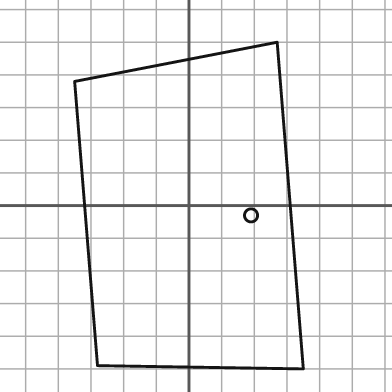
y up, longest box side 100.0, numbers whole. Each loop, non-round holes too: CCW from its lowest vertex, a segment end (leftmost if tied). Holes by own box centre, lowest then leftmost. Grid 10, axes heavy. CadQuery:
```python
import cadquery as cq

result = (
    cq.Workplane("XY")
    .moveTo(35.0, -50.0)
    .lineTo(27.0, 50.0)
    .lineTo(-35.0, 38.0)
    .lineTo(-28.0, -49.0)
    .close()
    .moveTo(19.0, -3.0)
    .circle(2.0)
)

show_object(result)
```